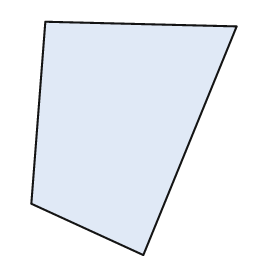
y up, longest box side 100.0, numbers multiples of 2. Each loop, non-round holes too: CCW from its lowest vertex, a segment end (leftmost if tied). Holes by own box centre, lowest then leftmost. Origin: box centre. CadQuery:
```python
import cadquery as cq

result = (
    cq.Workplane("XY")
    .moveTo(4.0, -50.0)
    .lineTo(44.0, 48.0)
    .lineTo(-38.0, 50.0)
    .lineTo(-44.0, -28.0)
    .close()
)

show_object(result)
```